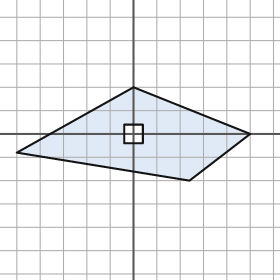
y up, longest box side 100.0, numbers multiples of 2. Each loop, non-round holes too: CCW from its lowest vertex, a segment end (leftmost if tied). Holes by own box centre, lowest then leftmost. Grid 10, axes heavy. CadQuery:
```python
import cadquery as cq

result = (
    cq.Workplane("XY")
    .moveTo(24.0, -20.0)
    .lineTo(50.0, 0.0)
    .lineTo(0.0, 20.0)
    .lineTo(-50.0, -8.0)
    .close()
    .moveTo(-4.0, -4.0)
    .lineTo(4.0, -4.0)
    .lineTo(4.0, 4.0)
    .lineTo(-4.0, 4.0)
    .close()
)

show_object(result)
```